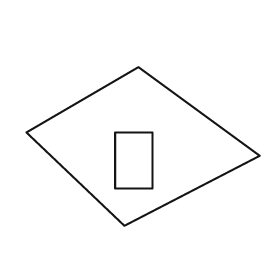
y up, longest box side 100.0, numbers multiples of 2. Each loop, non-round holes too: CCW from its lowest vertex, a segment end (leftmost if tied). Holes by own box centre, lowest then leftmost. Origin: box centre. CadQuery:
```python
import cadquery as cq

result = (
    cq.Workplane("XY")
    .moveTo(-8.0, -34.0)
    .lineTo(50.0, -4.0)
    .lineTo(-2.0, 34.0)
    .lineTo(-50.0, 6.0)
    .close()
    .moveTo(-12.0, -18.0)
    .lineTo(4.0, -18.0)
    .lineTo(4.0, 6.0)
    .lineTo(-12.0, 6.0)
    .close()
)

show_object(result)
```